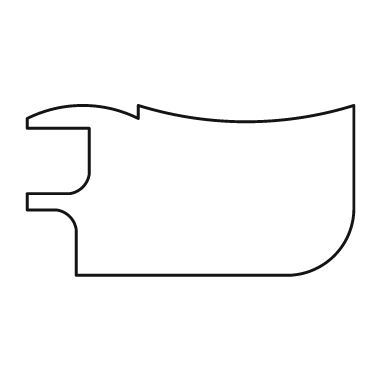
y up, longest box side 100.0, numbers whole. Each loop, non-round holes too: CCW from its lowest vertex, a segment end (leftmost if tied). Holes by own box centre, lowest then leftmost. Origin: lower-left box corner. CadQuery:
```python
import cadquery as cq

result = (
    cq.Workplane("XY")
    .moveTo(15.0, 0.0)
    .lineTo(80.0, 0.0)
    .threePointArc((94.0, 6.0), (100.0, 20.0))
    .lineTo(100.0, 52.0)
    .threePointArc((67.0, 47.0), (34.0, 52.0))
    .lineTo(34.0, 48.0)
    .threePointArc((17.0, 52.0), (0.0, 48.0))
    .lineTo(0.0, 45.0)
    .lineTo(19.0, 45.0)
    .lineTo(19.0, 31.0)
    .threePointArc((17.0, 27.0), (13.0, 25.0))
    .lineTo(0.0, 25.0)
    .lineTo(0.0, 20.0)
    .lineTo(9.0, 20.0)
    .threePointArc((13.0, 18.0), (15.0, 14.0))
    .close()
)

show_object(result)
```